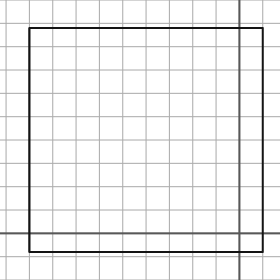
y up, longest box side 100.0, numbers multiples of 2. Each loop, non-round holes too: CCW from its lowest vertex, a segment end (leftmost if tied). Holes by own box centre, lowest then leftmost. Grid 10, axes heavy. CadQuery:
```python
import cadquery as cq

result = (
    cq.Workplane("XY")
    .moveTo(-90.0, -8.0)
    .lineTo(10.0, -8.0)
    .lineTo(10.0, 88.0)
    .lineTo(-90.0, 88.0)
    .close()
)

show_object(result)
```